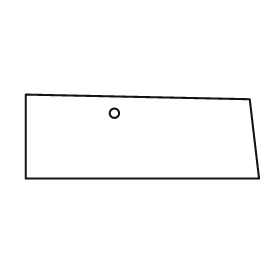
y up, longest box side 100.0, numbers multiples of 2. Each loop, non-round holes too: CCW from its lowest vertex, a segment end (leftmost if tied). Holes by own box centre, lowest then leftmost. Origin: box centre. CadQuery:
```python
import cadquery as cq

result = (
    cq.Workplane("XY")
    .moveTo(-50.0, -18.0)
    .lineTo(50.0, -18.0)
    .lineTo(46.0, 16.0)
    .lineTo(-50.0, 18.0)
    .close()
    .moveTo(-12.0, 10.0)
    .circle(2.0)
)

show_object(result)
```